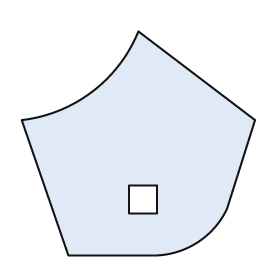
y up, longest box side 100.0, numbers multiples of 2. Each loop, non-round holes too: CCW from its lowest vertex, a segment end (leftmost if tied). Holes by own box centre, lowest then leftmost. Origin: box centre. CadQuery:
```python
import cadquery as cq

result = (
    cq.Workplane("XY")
    .moveTo(-30.0, -48.0)
    .lineTo(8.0, -48.0)
    .threePointArc((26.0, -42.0), (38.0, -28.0))
    .lineTo(50.0, 10.0)
    .lineTo(0.0, 48.0)
    .threePointArc((-20.0, 22.0), (-50.0, 10.0))
    .close()
    .moveTo(-4.0, -30.0)
    .lineTo(8.0, -30.0)
    .lineTo(8.0, -18.0)
    .lineTo(-4.0, -18.0)
    .close()
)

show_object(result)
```